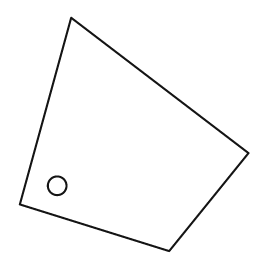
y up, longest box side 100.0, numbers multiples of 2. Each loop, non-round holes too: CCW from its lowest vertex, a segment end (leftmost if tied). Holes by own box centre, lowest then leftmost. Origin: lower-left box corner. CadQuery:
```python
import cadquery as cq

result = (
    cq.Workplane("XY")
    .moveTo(64.0, 0.0)
    .lineTo(98.0, 42.0)
    .lineTo(22.0, 100.0)
    .lineTo(0.0, 20.0)
    .close()
    .moveTo(16.0, 28.0)
    .circle(4.0)
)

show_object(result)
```